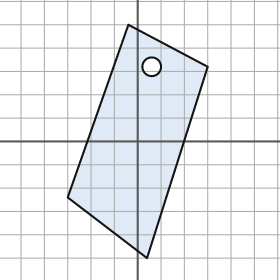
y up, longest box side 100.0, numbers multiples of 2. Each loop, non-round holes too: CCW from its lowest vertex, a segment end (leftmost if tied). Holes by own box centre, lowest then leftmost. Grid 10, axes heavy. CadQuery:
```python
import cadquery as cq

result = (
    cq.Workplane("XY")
    .moveTo(4.0, -50.0)
    .lineTo(30.0, 32.0)
    .lineTo(-4.0, 50.0)
    .lineTo(-30.0, -24.0)
    .close()
    .moveTo(6.0, 32.0)
    .circle(4.0)
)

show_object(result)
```